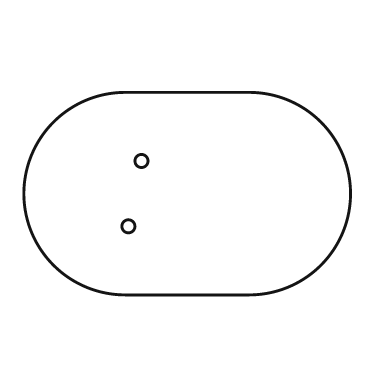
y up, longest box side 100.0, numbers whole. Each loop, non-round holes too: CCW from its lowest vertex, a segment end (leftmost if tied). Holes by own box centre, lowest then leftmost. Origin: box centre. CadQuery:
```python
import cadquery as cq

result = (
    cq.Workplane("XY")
    .moveTo(-19.0, -31.0)
    .lineTo(19.0, -31.0)
    .threePointArc((50.0, 0.0), (19.0, 31.0))
    .lineTo(-19.0, 31.0)
    .threePointArc((-50.0, 0.0), (-19.0, -31.0))
    .close()
    .moveTo(-18.0, -10.0)
    .circle(2.0)
    .moveTo(-14.0, 10.0)
    .circle(2.0)
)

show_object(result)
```